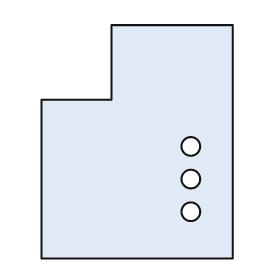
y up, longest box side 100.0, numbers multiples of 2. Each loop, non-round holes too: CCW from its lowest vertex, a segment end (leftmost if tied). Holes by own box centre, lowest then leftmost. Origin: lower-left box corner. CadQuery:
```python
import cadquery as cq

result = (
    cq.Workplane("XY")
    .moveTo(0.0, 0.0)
    .lineTo(82.0, 0.0)
    .lineTo(82.0, 100.0)
    .lineTo(30.0, 100.0)
    .lineTo(30.0, 68.0)
    .lineTo(0.0, 68.0)
    .close()
    .moveTo(64.0, 20.0)
    .circle(4.0)
    .moveTo(64.0, 34.0)
    .circle(4.0)
    .moveTo(64.0, 48.0)
    .circle(4.0)
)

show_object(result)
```